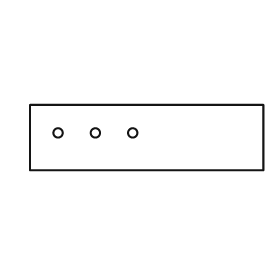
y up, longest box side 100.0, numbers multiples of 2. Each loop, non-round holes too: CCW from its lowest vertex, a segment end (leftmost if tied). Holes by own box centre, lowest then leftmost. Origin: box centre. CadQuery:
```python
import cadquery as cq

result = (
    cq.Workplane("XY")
    .moveTo(-50.0, -14.0)
    .lineTo(50.0, -14.0)
    .lineTo(50.0, 14.0)
    .lineTo(-50.0, 14.0)
    .close()
    .moveTo(-38.0, 2.0)
    .circle(2.0)
    .moveTo(-22.0, 2.0)
    .circle(2.0)
    .moveTo(-6.0, 2.0)
    .circle(2.0)
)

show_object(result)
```